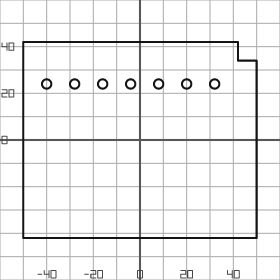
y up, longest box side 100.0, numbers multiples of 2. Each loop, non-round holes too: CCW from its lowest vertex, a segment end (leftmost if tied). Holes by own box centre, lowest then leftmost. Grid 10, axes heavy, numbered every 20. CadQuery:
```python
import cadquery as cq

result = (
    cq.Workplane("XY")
    .moveTo(-50.0, -42.0)
    .lineTo(50.0, -42.0)
    .lineTo(50.0, 34.0)
    .lineTo(42.0, 34.0)
    .lineTo(42.0, 42.0)
    .lineTo(-50.0, 42.0)
    .close()
    .moveTo(-40.0, 24.0)
    .circle(2.0)
    .moveTo(-28.0, 24.0)
    .circle(2.0)
    .moveTo(-16.0, 24.0)
    .circle(2.0)
    .moveTo(-4.0, 24.0)
    .circle(2.0)
    .moveTo(8.0, 24.0)
    .circle(2.0)
    .moveTo(20.0, 24.0)
    .circle(2.0)
    .moveTo(32.0, 24.0)
    .circle(2.0)
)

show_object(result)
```